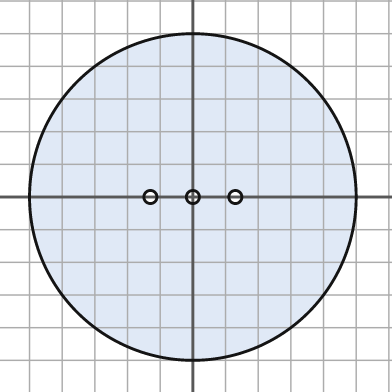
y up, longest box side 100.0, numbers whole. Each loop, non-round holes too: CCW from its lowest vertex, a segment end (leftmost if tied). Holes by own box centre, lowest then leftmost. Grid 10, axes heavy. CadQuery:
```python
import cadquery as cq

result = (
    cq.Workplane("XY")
    .moveTo(0.0, 0.0)
    .circle(50.0)
    .moveTo(-13.0, 0.0)
    .circle(2.0)
    .moveTo(0.0, 0.0)
    .circle(2.0)
    .moveTo(13.0, 0.0)
    .circle(2.0)
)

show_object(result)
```